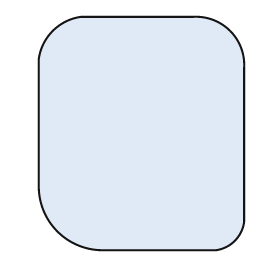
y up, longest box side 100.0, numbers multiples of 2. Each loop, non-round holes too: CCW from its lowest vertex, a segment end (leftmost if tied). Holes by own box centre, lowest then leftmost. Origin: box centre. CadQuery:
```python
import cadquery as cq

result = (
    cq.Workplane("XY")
    .moveTo(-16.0, -50.0)
    .lineTo(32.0, -50.0)
    .threePointArc((40.0, -46.0), (44.0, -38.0))
    .lineTo(44.0, 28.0)
    .threePointArc((38.0, 44.0), (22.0, 50.0))
    .lineTo(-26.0, 50.0)
    .threePointArc((-38.0, 44.0), (-44.0, 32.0))
    .lineTo(-44.0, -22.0)
    .threePointArc((-36.0, -42.0), (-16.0, -50.0))
    .close()
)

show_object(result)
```